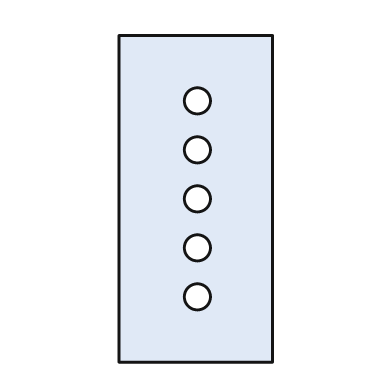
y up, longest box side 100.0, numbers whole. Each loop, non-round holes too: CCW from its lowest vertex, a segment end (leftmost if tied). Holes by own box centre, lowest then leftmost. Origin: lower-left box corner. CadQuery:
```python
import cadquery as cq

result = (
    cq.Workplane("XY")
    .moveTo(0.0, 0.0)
    .lineTo(47.0, 0.0)
    .lineTo(47.0, 100.0)
    .lineTo(0.0, 100.0)
    .close()
    .moveTo(24.0, 20.0)
    .circle(4.0)
    .moveTo(24.0, 35.0)
    .circle(4.0)
    .moveTo(24.0, 50.0)
    .circle(4.0)
    .moveTo(24.0, 65.0)
    .circle(4.0)
    .moveTo(24.0, 80.0)
    .circle(4.0)
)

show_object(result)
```